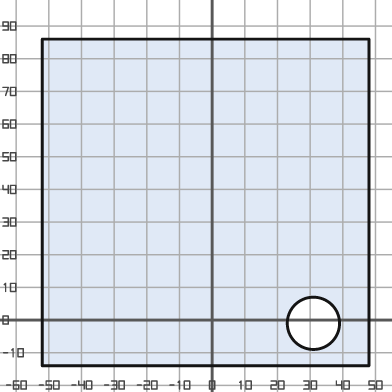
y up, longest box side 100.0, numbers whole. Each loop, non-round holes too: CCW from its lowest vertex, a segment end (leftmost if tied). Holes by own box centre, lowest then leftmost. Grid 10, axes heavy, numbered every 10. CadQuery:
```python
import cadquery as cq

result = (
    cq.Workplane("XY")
    .moveTo(-52.0, -14.0)
    .lineTo(48.0, -14.0)
    .lineTo(48.0, 86.0)
    .lineTo(-52.0, 86.0)
    .close()
    .moveTo(31.0, -1.0)
    .circle(8.0)
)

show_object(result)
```